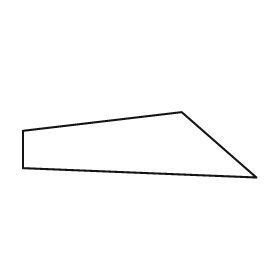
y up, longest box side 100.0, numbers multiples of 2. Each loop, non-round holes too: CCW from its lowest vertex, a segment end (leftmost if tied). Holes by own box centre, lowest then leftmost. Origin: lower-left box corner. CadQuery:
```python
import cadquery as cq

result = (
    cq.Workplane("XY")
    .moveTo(100.0, 0.0)
    .lineTo(68.0, 28.0)
    .lineTo(0.0, 20.0)
    .lineTo(0.0, 4.0)
    .close()
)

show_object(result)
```